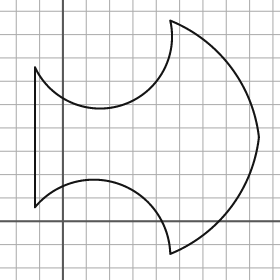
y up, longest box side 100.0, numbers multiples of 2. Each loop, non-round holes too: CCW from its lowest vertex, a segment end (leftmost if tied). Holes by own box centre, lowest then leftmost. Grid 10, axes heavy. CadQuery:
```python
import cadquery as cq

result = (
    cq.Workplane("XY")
    .moveTo(46.0, -14.0)
    .threePointArc((72.0, 6.0), (84.0, 36.0))
    .threePointArc((72.0, 66.0), (46.0, 86.0))
    .threePointArc((26.0, 50.0), (-12.0, 66.0))
    .lineTo(-12.0, 6.0)
    .threePointArc((24.0, 16.0), (46.0, -14.0))
    .close()
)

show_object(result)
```